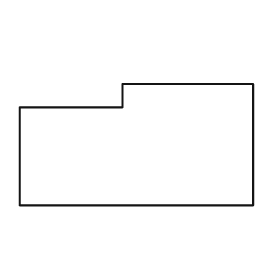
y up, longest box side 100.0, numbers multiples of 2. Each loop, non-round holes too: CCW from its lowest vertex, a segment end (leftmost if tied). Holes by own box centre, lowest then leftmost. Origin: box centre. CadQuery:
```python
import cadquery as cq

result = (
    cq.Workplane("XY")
    .moveTo(-50.0, -26.0)
    .lineTo(50.0, -26.0)
    .lineTo(50.0, 26.0)
    .lineTo(-6.0, 26.0)
    .lineTo(-6.0, 16.0)
    .lineTo(-50.0, 16.0)
    .close()
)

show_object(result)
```